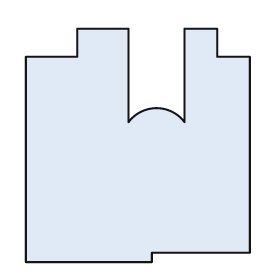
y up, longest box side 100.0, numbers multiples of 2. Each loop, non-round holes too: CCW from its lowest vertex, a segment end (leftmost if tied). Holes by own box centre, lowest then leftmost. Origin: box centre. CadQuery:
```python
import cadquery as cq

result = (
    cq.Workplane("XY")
    .moveTo(-48.0, -50.0)
    .lineTo(6.0, -50.0)
    .lineTo(6.0, -46.0)
    .lineTo(48.0, -46.0)
    .lineTo(48.0, 38.0)
    .lineTo(34.0, 38.0)
    .lineTo(34.0, 50.0)
    .lineTo(20.0, 50.0)
    .lineTo(20.0, 10.0)
    .threePointArc((8.0, 16.0), (-4.0, 10.0))
    .lineTo(-4.0, 50.0)
    .lineTo(-26.0, 50.0)
    .lineTo(-26.0, 38.0)
    .lineTo(-48.0, 38.0)
    .close()
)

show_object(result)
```